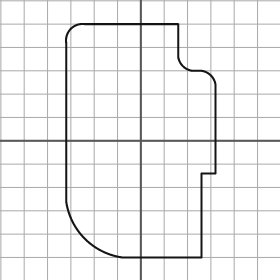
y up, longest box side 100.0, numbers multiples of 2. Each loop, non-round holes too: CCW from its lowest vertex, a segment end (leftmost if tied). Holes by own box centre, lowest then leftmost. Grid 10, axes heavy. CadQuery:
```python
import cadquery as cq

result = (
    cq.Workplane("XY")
    .moveTo(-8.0, -50.0)
    .lineTo(26.0, -50.0)
    .lineTo(26.0, -14.0)
    .lineTo(32.0, -14.0)
    .lineTo(32.0, 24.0)
    .threePointArc((30.0, 28.0), (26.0, 30.0))
    .lineTo(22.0, 30.0)
    .threePointArc((18.0, 32.0), (16.0, 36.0))
    .lineTo(16.0, 50.0)
    .lineTo(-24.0, 50.0)
    .threePointArc((-30.0, 48.0), (-32.0, 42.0))
    .lineTo(-32.0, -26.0)
    .threePointArc((-24.0, -42.0), (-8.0, -50.0))
    .close()
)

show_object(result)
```